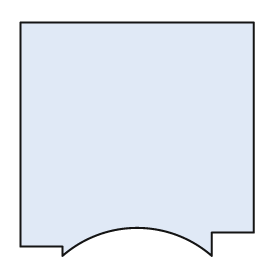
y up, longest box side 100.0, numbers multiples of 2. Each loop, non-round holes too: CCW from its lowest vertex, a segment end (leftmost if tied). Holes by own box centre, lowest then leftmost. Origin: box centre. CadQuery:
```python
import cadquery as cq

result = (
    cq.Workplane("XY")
    .moveTo(-32.0, -50.0)
    .threePointArc((0.0, -38.0), (32.0, -50.0))
    .lineTo(32.0, -40.0)
    .lineTo(50.0, -40.0)
    .lineTo(50.0, 50.0)
    .lineTo(-50.0, 50.0)
    .lineTo(-50.0, -46.0)
    .lineTo(-32.0, -46.0)
    .close()
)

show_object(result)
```